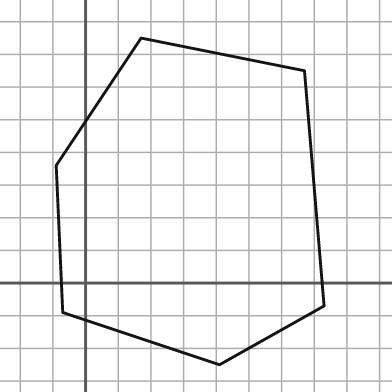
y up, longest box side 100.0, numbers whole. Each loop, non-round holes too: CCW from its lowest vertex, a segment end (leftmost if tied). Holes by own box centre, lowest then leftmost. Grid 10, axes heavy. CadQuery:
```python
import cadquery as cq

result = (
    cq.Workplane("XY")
    .moveTo(41.0, -25.0)
    .lineTo(73.0, -7.0)
    .lineTo(67.0, 65.0)
    .lineTo(17.0, 75.0)
    .lineTo(-9.0, 36.0)
    .lineTo(-7.0, -9.0)
    .close()
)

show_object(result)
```